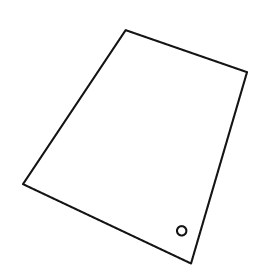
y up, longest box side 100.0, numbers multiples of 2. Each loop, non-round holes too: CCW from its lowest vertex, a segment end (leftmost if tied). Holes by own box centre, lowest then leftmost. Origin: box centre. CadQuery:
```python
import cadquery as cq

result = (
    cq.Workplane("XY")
    .moveTo(24.0, -50.0)
    .lineTo(48.0, 32.0)
    .lineTo(-4.0, 50.0)
    .lineTo(-48.0, -16.0)
    .close()
    .moveTo(20.0, -36.0)
    .circle(2.0)
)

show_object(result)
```